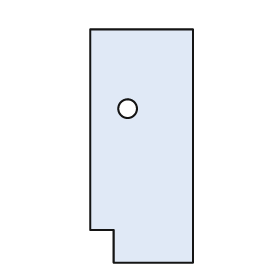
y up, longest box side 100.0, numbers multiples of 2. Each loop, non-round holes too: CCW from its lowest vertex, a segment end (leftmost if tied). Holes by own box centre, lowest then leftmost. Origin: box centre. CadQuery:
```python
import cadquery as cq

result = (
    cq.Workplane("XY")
    .moveTo(-12.0, -50.0)
    .lineTo(22.0, -50.0)
    .lineTo(22.0, 50.0)
    .lineTo(-22.0, 50.0)
    .lineTo(-22.0, -36.0)
    .lineTo(-12.0, -36.0)
    .close()
    .moveTo(-6.0, 16.0)
    .circle(4.0)
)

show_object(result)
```